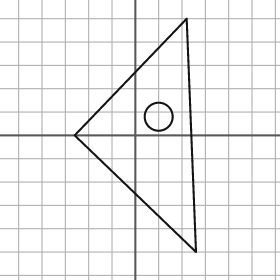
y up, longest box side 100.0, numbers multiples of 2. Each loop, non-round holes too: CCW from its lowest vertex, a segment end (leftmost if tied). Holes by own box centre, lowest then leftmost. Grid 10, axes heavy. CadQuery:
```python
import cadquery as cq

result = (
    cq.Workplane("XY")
    .moveTo(26.0, -50.0)
    .lineTo(22.0, 50.0)
    .lineTo(-26.0, 0.0)
    .close()
    .moveTo(10.0, 8.0)
    .circle(6.0)
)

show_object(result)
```